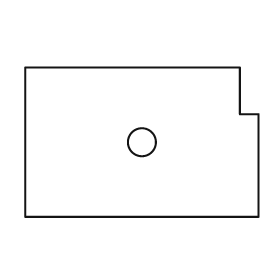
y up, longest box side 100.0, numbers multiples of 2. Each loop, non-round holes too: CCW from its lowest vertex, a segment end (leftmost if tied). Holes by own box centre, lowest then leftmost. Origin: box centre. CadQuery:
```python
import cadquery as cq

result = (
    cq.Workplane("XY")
    .moveTo(-50.0, -32.0)
    .lineTo(50.0, -32.0)
    .lineTo(50.0, 12.0)
    .lineTo(42.0, 12.0)
    .lineTo(42.0, 32.0)
    .lineTo(-50.0, 32.0)
    .close()
    .moveTo(0.0, 0.0)
    .circle(6.0)
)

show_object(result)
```